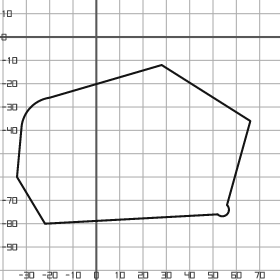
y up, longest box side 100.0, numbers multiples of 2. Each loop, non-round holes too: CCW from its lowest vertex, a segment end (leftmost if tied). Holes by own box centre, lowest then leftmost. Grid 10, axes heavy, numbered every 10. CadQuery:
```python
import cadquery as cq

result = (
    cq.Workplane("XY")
    .moveTo(-22.0, -80.0)
    .lineTo(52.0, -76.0)
    .threePointArc((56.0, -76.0), (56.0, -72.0))
    .lineTo(66.0, -36.0)
    .lineTo(28.0, -12.0)
    .lineTo(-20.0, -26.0)
    .threePointArc((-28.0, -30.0), (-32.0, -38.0))
    .lineTo(-34.0, -60.0)
    .close()
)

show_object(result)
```